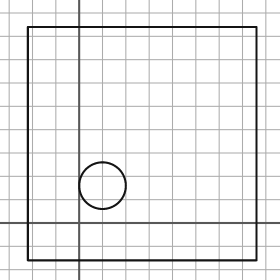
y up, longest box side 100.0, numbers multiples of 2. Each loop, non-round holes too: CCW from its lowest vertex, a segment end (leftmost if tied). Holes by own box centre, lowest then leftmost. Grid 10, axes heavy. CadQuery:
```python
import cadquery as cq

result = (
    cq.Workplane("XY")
    .moveTo(-22.0, -16.0)
    .lineTo(76.0, -16.0)
    .lineTo(76.0, 84.0)
    .lineTo(-22.0, 84.0)
    .close()
    .moveTo(10.0, 16.0)
    .circle(10.0)
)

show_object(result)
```